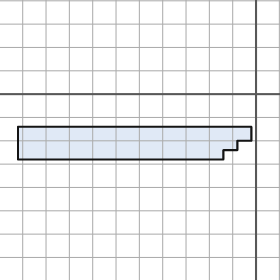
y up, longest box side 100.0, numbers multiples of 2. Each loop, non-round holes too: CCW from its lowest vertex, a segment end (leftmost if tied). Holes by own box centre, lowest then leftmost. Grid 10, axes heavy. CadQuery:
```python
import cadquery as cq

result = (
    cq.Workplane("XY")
    .moveTo(-102.0, -28.0)
    .lineTo(-14.0, -28.0)
    .lineTo(-14.0, -24.0)
    .lineTo(-8.0, -24.0)
    .lineTo(-8.0, -20.0)
    .lineTo(-2.0, -20.0)
    .lineTo(-2.0, -14.0)
    .lineTo(-102.0, -14.0)
    .close()
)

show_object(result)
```